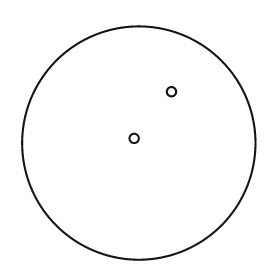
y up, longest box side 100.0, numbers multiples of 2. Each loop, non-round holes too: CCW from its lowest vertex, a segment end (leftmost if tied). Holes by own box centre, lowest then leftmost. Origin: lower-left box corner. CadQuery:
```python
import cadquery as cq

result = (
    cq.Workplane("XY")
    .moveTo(50.0, 50.0)
    .circle(50.0)
    .moveTo(48.0, 52.0)
    .circle(2.0)
    .moveTo(64.0, 72.0)
    .circle(2.0)
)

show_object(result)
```